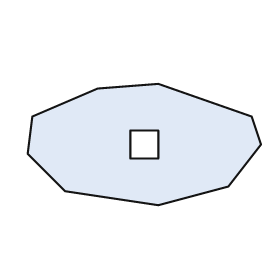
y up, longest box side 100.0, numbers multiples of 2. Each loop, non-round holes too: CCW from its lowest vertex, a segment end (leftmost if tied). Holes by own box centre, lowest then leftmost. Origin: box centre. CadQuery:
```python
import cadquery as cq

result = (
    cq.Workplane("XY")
    .moveTo(6.0, -26.0)
    .lineTo(36.0, -18.0)
    .lineTo(50.0, 0.0)
    .lineTo(46.0, 12.0)
    .lineTo(6.0, 26.0)
    .lineTo(-20.0, 24.0)
    .lineTo(-48.0, 12.0)
    .lineTo(-50.0, -4.0)
    .lineTo(-34.0, -20.0)
    .close()
    .moveTo(-6.0, -6.0)
    .lineTo(6.0, -6.0)
    .lineTo(6.0, 6.0)
    .lineTo(-6.0, 6.0)
    .close()
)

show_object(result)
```